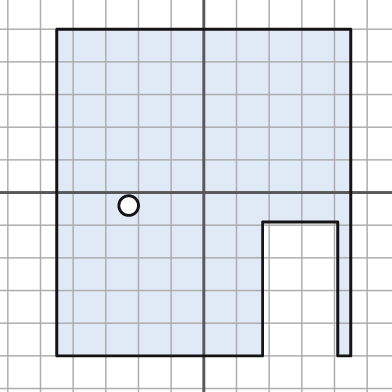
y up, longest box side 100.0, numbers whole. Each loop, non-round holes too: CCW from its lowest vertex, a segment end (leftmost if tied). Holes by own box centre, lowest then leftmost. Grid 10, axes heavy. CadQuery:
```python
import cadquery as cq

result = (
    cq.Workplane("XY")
    .moveTo(-45.0, -50.0)
    .lineTo(18.0, -50.0)
    .lineTo(18.0, -9.0)
    .lineTo(41.0, -9.0)
    .lineTo(41.0, -50.0)
    .lineTo(45.0, -50.0)
    .lineTo(45.0, 50.0)
    .lineTo(-45.0, 50.0)
    .close()
    .moveTo(-23.0, -4.0)
    .circle(3.0)
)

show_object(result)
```